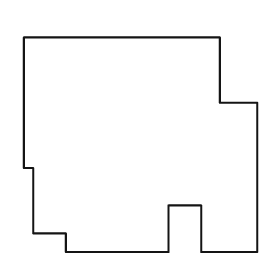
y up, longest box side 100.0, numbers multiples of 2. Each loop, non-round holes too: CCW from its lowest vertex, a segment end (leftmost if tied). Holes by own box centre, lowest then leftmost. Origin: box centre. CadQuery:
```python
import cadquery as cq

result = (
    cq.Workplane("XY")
    .moveTo(-32.0, -46.0)
    .lineTo(12.0, -46.0)
    .lineTo(12.0, -26.0)
    .lineTo(26.0, -26.0)
    .lineTo(26.0, -46.0)
    .lineTo(50.0, -46.0)
    .lineTo(50.0, 18.0)
    .lineTo(34.0, 18.0)
    .lineTo(34.0, 46.0)
    .lineTo(-50.0, 46.0)
    .lineTo(-50.0, -10.0)
    .lineTo(-46.0, -10.0)
    .lineTo(-46.0, -38.0)
    .lineTo(-32.0, -38.0)
    .close()
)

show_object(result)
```